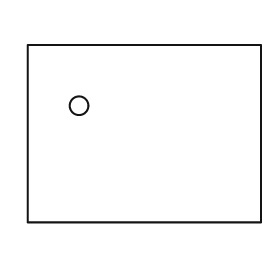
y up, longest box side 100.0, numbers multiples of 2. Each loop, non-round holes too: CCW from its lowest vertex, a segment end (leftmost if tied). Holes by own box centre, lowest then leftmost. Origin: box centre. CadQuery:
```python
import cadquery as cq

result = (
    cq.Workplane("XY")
    .moveTo(-50.0, -38.0)
    .lineTo(50.0, -38.0)
    .lineTo(50.0, 38.0)
    .lineTo(-50.0, 38.0)
    .close()
    .moveTo(-28.0, 12.0)
    .circle(4.0)
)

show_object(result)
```